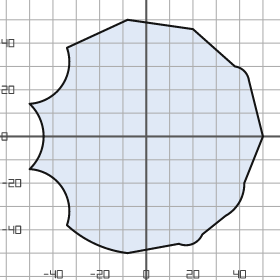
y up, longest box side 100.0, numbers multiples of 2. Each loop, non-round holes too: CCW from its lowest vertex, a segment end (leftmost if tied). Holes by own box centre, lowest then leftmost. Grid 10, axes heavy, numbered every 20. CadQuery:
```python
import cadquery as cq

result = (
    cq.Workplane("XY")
    .moveTo(-8.0, -50.0)
    .lineTo(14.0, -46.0)
    .threePointArc((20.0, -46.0), (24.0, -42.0))
    .lineTo(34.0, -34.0)
    .threePointArc((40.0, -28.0), (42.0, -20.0))
    .lineTo(50.0, 0.0)
    .lineTo(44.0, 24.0)
    .threePointArc((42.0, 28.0), (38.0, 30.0))
    .lineTo(20.0, 46.0)
    .lineTo(-8.0, 50.0)
    .lineTo(-34.0, 38.0)
    .threePointArc((-36.0, 22.0), (-50.0, 14.0))
    .threePointArc((-44.0, 0.0), (-50.0, -14.0))
    .threePointArc((-36.0, -22.0), (-34.0, -38.0))
    .threePointArc((-22.0, -46.0), (-8.0, -50.0))
    .close()
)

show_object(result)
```